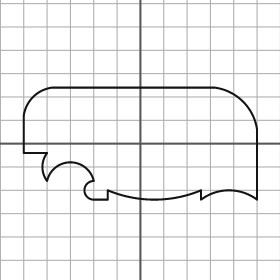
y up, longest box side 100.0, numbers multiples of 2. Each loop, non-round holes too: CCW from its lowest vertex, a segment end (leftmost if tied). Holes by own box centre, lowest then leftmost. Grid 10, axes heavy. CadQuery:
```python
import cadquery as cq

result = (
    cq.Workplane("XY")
    .moveTo(-20.0, -24.0)
    .lineTo(-14.0, -24.0)
    .lineTo(-14.0, -20.0)
    .threePointArc((6.0, -24.0), (26.0, -20.0))
    .lineTo(26.0, -24.0)
    .threePointArc((38.0, -20.0), (50.0, -24.0))
    .lineTo(50.0, 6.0)
    .threePointArc((44.0, 18.0), (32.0, 24.0))
    .lineTo(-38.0, 24.0)
    .threePointArc((-46.0, 20.0), (-50.0, 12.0))
    .lineTo(-50.0, -4.0)
    .lineTo(-40.0, -4.0)
    .threePointArc((-42.0, -10.0), (-40.0, -16.0))
    .threePointArc((-30.0, -8.0), (-20.0, -16.0))
    .threePointArc((-24.0, -20.0), (-20.0, -24.0))
    .close()
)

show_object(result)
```